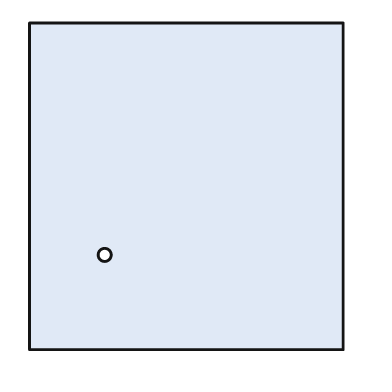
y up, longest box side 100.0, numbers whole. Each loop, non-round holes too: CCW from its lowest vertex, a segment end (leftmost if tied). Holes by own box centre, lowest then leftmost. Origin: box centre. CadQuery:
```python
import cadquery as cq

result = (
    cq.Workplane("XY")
    .moveTo(-48.0, -50.0)
    .lineTo(48.0, -50.0)
    .lineTo(48.0, 50.0)
    .lineTo(-48.0, 50.0)
    .close()
    .moveTo(-25.0, -21.0)
    .circle(2.0)
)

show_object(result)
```